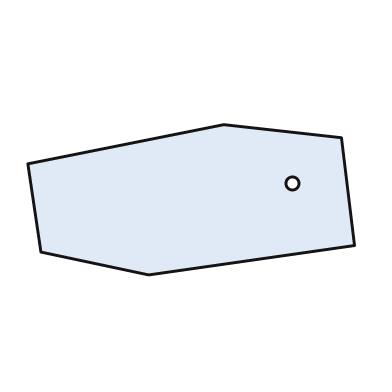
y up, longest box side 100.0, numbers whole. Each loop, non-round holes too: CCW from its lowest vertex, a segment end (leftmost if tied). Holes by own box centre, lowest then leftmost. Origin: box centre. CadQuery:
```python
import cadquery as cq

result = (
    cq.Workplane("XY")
    .moveTo(-13.0, -23.0)
    .lineTo(50.0, -14.0)
    .lineTo(46.0, 19.0)
    .lineTo(10.0, 23.0)
    .lineTo(-50.0, 11.0)
    .lineTo(-46.0, -16.0)
    .close()
    .moveTo(31.0, 5.0)
    .circle(2.0)
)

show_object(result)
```